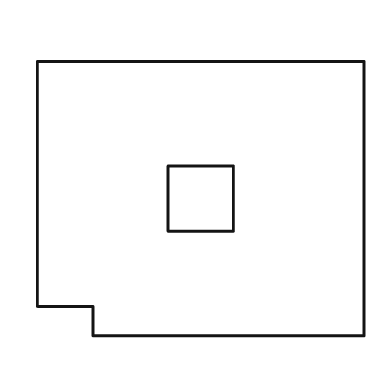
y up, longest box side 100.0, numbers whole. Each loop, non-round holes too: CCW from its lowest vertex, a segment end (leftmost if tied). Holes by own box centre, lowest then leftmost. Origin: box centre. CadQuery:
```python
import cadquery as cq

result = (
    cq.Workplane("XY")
    .moveTo(-33.0, -42.0)
    .lineTo(50.0, -42.0)
    .lineTo(50.0, 42.0)
    .lineTo(-50.0, 42.0)
    .lineTo(-50.0, -33.0)
    .lineTo(-33.0, -33.0)
    .close()
    .moveTo(-10.0, -10.0)
    .lineTo(10.0, -10.0)
    .lineTo(10.0, 10.0)
    .lineTo(-10.0, 10.0)
    .close()
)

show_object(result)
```